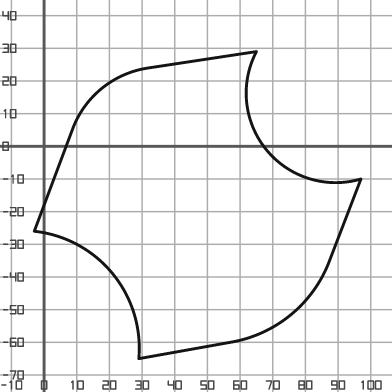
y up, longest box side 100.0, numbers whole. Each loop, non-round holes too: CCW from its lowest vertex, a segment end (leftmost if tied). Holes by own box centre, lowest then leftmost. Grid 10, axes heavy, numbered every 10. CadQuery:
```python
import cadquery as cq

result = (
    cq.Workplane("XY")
    .moveTo(29.0, -65.0)
    .lineTo(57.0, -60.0)
    .threePointArc((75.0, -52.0), (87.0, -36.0))
    .lineTo(97.0, -10.0)
    .threePointArc((68.0, -1.0), (65.0, 29.0))
    .lineTo(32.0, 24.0)
    .threePointArc((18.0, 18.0), (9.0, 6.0))
    .lineTo(-3.0, -26.0)
    .threePointArc((21.0, -39.0), (29.0, -65.0))
    .close()
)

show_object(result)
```